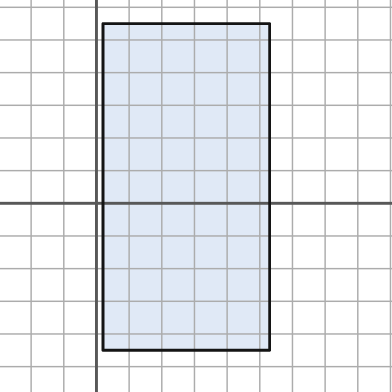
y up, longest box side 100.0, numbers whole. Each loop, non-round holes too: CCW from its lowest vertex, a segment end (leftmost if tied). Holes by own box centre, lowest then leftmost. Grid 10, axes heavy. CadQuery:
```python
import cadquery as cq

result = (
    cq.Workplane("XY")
    .moveTo(2.0, -45.0)
    .lineTo(53.0, -45.0)
    .lineTo(53.0, 55.0)
    .lineTo(2.0, 55.0)
    .close()
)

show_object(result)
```